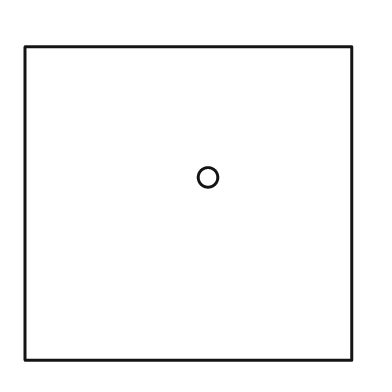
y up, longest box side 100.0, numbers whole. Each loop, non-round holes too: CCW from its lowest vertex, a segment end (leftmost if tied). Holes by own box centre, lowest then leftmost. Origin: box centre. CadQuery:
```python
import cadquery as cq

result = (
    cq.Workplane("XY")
    .moveTo(-50.0, -48.0)
    .lineTo(50.0, -48.0)
    .lineTo(50.0, 48.0)
    .lineTo(-50.0, 48.0)
    .close()
    .moveTo(6.0, 8.0)
    .circle(3.0)
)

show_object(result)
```